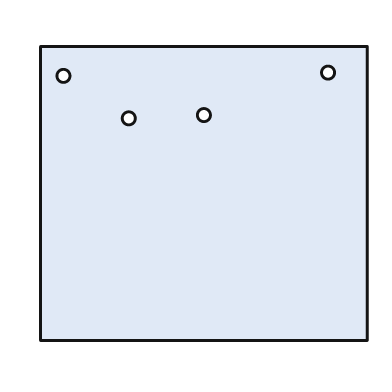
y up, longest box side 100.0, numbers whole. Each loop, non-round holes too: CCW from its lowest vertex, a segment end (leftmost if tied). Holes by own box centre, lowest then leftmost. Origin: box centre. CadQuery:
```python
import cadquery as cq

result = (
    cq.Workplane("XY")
    .moveTo(-50.0, -45.0)
    .lineTo(50.0, -45.0)
    .lineTo(50.0, 45.0)
    .lineTo(-50.0, 45.0)
    .close()
    .moveTo(-23.0, 23.0)
    .circle(2.0)
    .moveTo(0.0, 24.0)
    .circle(2.0)
    .moveTo(-43.0, 36.0)
    .circle(2.0)
    .moveTo(38.0, 37.0)
    .circle(2.0)
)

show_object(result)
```